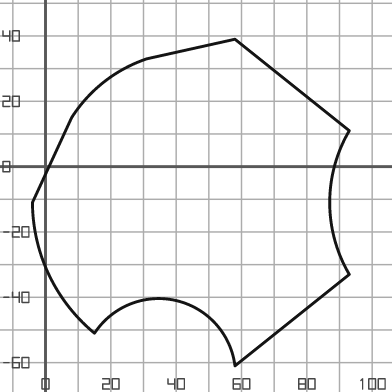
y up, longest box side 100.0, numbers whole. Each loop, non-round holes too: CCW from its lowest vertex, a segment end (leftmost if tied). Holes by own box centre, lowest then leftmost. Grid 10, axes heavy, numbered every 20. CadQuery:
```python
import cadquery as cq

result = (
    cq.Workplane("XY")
    .moveTo(58.0, -61.0)
    .lineTo(93.0, -33.0)
    .threePointArc((87.0, -11.0), (93.0, 11.0))
    .lineTo(58.0, 39.0)
    .lineTo(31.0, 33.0)
    .threePointArc((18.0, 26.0), (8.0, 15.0))
    .lineTo(-4.0, -11.0)
    .threePointArc((1.0, -33.0), (15.0, -51.0))
    .threePointArc((40.0, -41.0), (58.0, -61.0))
    .close()
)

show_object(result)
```